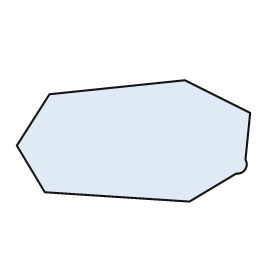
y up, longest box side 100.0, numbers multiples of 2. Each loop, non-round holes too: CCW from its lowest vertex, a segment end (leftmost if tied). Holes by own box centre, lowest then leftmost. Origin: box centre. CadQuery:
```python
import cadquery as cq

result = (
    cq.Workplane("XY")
    .moveTo(24.0, -26.0)
    .lineTo(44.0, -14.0)
    .threePointArc((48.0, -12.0), (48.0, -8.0))
    .lineTo(50.0, 12.0)
    .lineTo(22.0, 26.0)
    .lineTo(-36.0, 20.0)
    .lineTo(-50.0, -2.0)
    .lineTo(-38.0, -22.0)
    .close()
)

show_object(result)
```